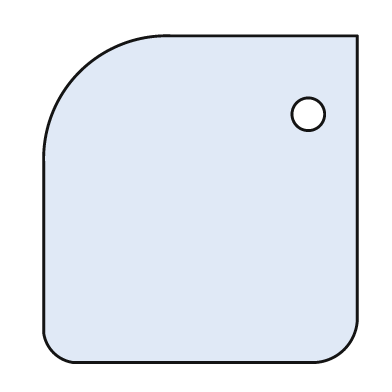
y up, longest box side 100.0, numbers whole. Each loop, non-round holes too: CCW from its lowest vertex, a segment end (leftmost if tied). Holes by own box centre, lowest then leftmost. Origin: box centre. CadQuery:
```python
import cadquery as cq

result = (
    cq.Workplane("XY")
    .moveTo(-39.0, -50.0)
    .lineTo(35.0, -50.0)
    .threePointArc((44.0, -46.0), (48.0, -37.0))
    .lineTo(48.0, 50.0)
    .lineTo(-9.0, 50.0)
    .threePointArc((-37.0, 39.0), (-48.0, 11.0))
    .lineTo(-48.0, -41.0)
    .threePointArc((-45.0, -47.0), (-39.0, -50.0))
    .close()
    .moveTo(33.0, 26.0)
    .circle(5.0)
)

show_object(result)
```